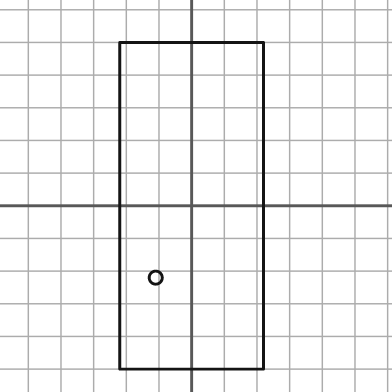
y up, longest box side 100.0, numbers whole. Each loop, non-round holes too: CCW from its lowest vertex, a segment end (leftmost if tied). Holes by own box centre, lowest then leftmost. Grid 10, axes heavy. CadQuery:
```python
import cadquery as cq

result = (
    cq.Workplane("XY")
    .moveTo(-22.0, -50.0)
    .lineTo(22.0, -50.0)
    .lineTo(22.0, 50.0)
    .lineTo(-22.0, 50.0)
    .close()
    .moveTo(-11.0, -22.0)
    .circle(2.0)
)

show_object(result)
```